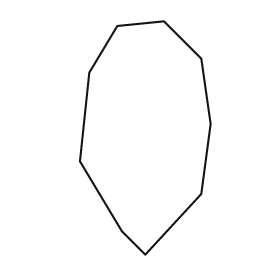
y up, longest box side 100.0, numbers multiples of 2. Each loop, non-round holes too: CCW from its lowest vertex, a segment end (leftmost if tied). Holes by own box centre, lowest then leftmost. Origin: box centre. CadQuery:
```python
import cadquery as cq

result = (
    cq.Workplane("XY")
    .moveTo(0.0, -50.0)
    .lineTo(24.0, -24.0)
    .lineTo(28.0, 6.0)
    .lineTo(24.0, 34.0)
    .lineTo(8.0, 50.0)
    .lineTo(-12.0, 48.0)
    .lineTo(-24.0, 28.0)
    .lineTo(-28.0, -10.0)
    .lineTo(-10.0, -40.0)
    .close()
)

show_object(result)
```